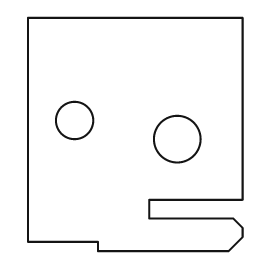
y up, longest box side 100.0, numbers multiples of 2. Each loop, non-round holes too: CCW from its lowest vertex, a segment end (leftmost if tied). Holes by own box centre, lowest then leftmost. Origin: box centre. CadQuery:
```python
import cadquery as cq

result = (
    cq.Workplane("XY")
    .moveTo(-16.0, -50.0)
    .lineTo(40.0, -50.0)
    .lineTo(46.0, -44.0)
    .lineTo(46.0, -40.0)
    .lineTo(42.0, -36.0)
    .lineTo(6.0, -36.0)
    .lineTo(6.0, -28.0)
    .lineTo(46.0, -28.0)
    .lineTo(46.0, 50.0)
    .lineTo(-46.0, 50.0)
    .lineTo(-46.0, -46.0)
    .lineTo(-16.0, -46.0)
    .close()
    .moveTo(18.0, -2.0)
    .circle(10.0)
    .moveTo(-26.0, 6.0)
    .circle(8.0)
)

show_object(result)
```